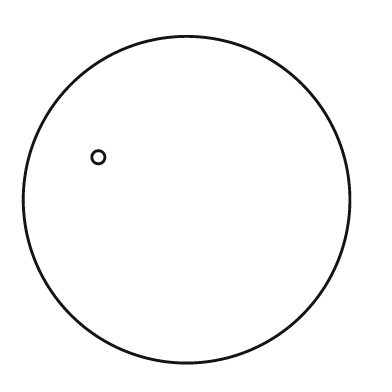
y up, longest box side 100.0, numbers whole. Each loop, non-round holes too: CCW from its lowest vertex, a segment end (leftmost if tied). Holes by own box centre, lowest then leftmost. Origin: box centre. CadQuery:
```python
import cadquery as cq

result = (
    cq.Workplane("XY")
    .moveTo(0.0, 0.0)
    .circle(50.0)
    .moveTo(-27.0, 13.0)
    .circle(2.0)
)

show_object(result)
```